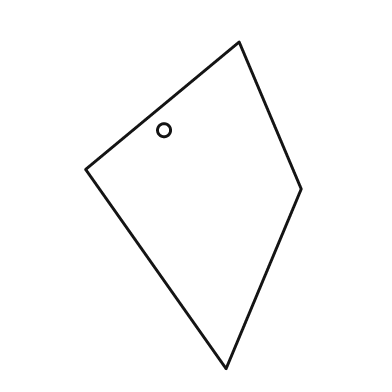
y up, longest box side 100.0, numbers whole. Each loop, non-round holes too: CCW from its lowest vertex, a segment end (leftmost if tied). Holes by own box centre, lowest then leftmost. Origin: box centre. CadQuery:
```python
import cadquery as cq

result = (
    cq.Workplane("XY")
    .moveTo(10.0, -50.0)
    .lineTo(33.0, 5.0)
    .lineTo(14.0, 50.0)
    .lineTo(-33.0, 11.0)
    .close()
    .moveTo(-9.0, 23.0)
    .circle(2.0)
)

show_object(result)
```